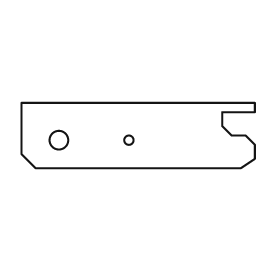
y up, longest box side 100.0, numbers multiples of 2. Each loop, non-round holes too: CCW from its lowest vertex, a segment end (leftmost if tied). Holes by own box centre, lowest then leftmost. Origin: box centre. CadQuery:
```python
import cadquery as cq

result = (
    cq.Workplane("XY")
    .moveTo(-44.0, -14.0)
    .lineTo(44.0, -14.0)
    .lineTo(50.0, -10.0)
    .lineTo(50.0, -4.0)
    .lineTo(46.0, 0.0)
    .lineTo(40.0, 0.0)
    .lineTo(36.0, 4.0)
    .lineTo(36.0, 10.0)
    .lineTo(50.0, 10.0)
    .lineTo(50.0, 14.0)
    .lineTo(-50.0, 14.0)
    .lineTo(-50.0, -8.0)
    .close()
    .moveTo(-34.0, -2.0)
    .circle(4.0)
    .moveTo(-4.0, -2.0)
    .circle(2.0)
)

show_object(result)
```